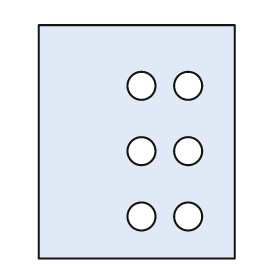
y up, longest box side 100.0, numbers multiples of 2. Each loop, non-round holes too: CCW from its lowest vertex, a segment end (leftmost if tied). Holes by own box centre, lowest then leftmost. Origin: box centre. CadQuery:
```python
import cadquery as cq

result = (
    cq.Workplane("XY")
    .moveTo(-42.0, -50.0)
    .lineTo(42.0, -50.0)
    .lineTo(42.0, 50.0)
    .lineTo(-42.0, 50.0)
    .close()
    .moveTo(2.0, -32.0)
    .circle(6.0)
    .moveTo(22.0, -32.0)
    .circle(6.0)
    .moveTo(2.0, -4.0)
    .circle(6.0)
    .moveTo(22.0, -4.0)
    .circle(6.0)
    .moveTo(2.0, 24.0)
    .circle(6.0)
    .moveTo(22.0, 24.0)
    .circle(6.0)
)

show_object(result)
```